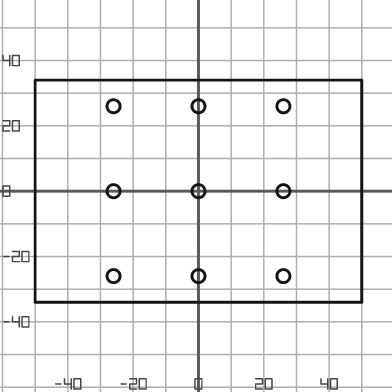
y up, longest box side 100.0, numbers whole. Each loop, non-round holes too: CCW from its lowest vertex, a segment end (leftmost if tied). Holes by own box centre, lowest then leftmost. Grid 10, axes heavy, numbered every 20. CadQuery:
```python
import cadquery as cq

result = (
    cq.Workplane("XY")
    .moveTo(-50.0, -34.0)
    .lineTo(50.0, -34.0)
    .lineTo(50.0, 34.0)
    .lineTo(-50.0, 34.0)
    .close()
    .moveTo(-26.0, -26.0)
    .circle(2.0)
    .moveTo(0.0, -26.0)
    .circle(2.0)
    .moveTo(26.0, -26.0)
    .circle(2.0)
    .moveTo(-26.0, 0.0)
    .circle(2.0)
    .moveTo(0.0, 0.0)
    .circle(2.0)
    .moveTo(26.0, 0.0)
    .circle(2.0)
    .moveTo(-26.0, 26.0)
    .circle(2.0)
    .moveTo(0.0, 26.0)
    .circle(2.0)
    .moveTo(26.0, 26.0)
    .circle(2.0)
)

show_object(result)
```